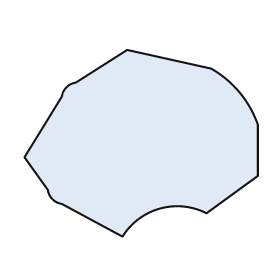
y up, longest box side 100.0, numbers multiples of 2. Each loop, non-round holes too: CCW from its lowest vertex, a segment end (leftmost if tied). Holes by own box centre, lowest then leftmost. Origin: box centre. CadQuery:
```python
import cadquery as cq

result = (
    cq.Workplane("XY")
    .moveTo(-8.0, -40.0)
    .threePointArc((8.0, -28.0), (28.0, -30.0))
    .lineTo(50.0, -14.0)
    .lineTo(50.0, 8.0)
    .threePointArc((42.0, 22.0), (30.0, 32.0))
    .lineTo(-6.0, 40.0)
    .lineTo(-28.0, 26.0)
    .threePointArc((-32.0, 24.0), (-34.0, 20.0))
    .lineTo(-50.0, -6.0)
    .lineTo(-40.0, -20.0)
    .threePointArc((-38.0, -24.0), (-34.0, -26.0))
    .close()
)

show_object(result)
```